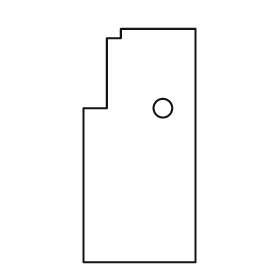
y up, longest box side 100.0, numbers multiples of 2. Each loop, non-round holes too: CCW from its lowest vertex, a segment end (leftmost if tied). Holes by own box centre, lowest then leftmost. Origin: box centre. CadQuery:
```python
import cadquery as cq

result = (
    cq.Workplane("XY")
    .moveTo(-24.0, -50.0)
    .lineTo(24.0, -50.0)
    .lineTo(24.0, 50.0)
    .lineTo(-8.0, 50.0)
    .lineTo(-8.0, 46.0)
    .lineTo(-14.0, 46.0)
    .lineTo(-14.0, 16.0)
    .lineTo(-24.0, 16.0)
    .close()
    .moveTo(10.0, 16.0)
    .circle(4.0)
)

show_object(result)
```